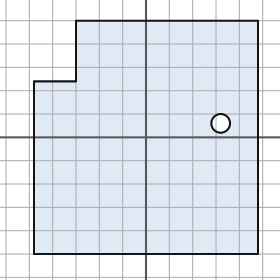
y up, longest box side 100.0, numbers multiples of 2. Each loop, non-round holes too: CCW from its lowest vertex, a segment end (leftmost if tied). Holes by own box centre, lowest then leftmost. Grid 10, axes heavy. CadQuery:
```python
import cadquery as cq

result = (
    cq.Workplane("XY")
    .moveTo(-48.0, -50.0)
    .lineTo(48.0, -50.0)
    .lineTo(48.0, 50.0)
    .lineTo(-30.0, 50.0)
    .lineTo(-30.0, 24.0)
    .lineTo(-48.0, 24.0)
    .close()
    .moveTo(32.0, 6.0)
    .circle(4.0)
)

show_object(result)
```